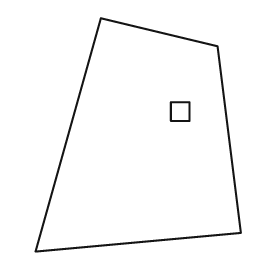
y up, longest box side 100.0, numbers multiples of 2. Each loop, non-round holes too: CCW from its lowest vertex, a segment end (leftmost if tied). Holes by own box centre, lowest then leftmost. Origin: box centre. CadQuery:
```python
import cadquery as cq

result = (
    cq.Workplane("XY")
    .moveTo(-44.0, -50.0)
    .lineTo(44.0, -42.0)
    .lineTo(34.0, 38.0)
    .lineTo(-16.0, 50.0)
    .close()
    .moveTo(14.0, 6.0)
    .lineTo(22.0, 6.0)
    .lineTo(22.0, 14.0)
    .lineTo(14.0, 14.0)
    .close()
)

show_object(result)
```